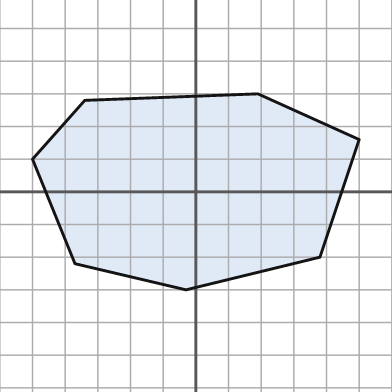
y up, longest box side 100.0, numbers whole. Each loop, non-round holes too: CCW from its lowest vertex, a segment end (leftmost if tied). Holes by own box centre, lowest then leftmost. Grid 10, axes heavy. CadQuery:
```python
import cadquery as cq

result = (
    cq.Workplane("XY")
    .moveTo(-3.0, -30.0)
    .lineTo(38.0, -20.0)
    .lineTo(50.0, 16.0)
    .lineTo(19.0, 30.0)
    .lineTo(-34.0, 28.0)
    .lineTo(-50.0, 10.0)
    .lineTo(-37.0, -22.0)
    .close()
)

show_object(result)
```